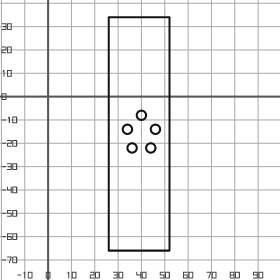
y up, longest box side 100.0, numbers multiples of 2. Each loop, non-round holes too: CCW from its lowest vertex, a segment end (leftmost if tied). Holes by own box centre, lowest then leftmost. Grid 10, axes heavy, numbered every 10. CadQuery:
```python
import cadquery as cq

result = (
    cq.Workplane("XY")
    .moveTo(26.0, -66.0)
    .lineTo(52.0, -66.0)
    .lineTo(52.0, 34.0)
    .lineTo(26.0, 34.0)
    .close()
    .moveTo(36.0, -22.0)
    .circle(2.0)
    .moveTo(44.0, -22.0)
    .circle(2.0)
    .moveTo(34.0, -14.0)
    .circle(2.0)
    .moveTo(46.0, -14.0)
    .circle(2.0)
    .moveTo(40.0, -8.0)
    .circle(2.0)
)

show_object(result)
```